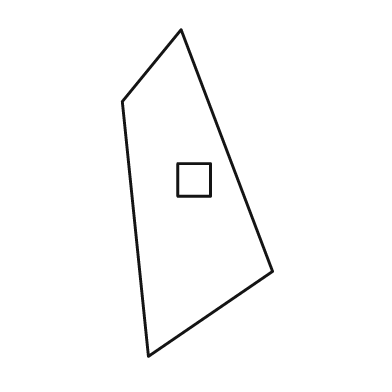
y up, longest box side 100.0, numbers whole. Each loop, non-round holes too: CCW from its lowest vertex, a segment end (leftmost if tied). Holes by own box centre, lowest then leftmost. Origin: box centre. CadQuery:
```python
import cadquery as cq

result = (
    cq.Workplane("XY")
    .moveTo(-15.0, -50.0)
    .lineTo(23.0, -24.0)
    .lineTo(-5.0, 50.0)
    .lineTo(-23.0, 28.0)
    .close()
    .moveTo(-6.0, -1.0)
    .lineTo(4.0, -1.0)
    .lineTo(4.0, 9.0)
    .lineTo(-6.0, 9.0)
    .close()
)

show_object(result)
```